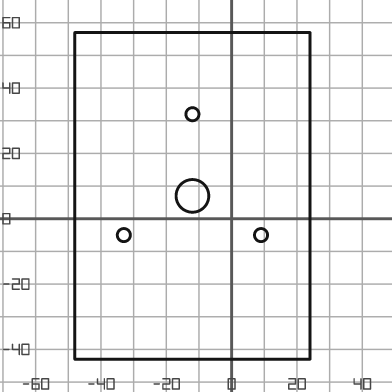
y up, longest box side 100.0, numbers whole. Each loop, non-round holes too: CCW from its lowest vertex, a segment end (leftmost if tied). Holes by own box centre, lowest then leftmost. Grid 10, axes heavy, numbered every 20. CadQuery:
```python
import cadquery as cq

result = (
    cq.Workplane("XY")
    .moveTo(-48.0, -43.0)
    .lineTo(24.0, -43.0)
    .lineTo(24.0, 57.0)
    .lineTo(-48.0, 57.0)
    .close()
    .moveTo(-33.0, -5.0)
    .circle(2.0)
    .moveTo(9.0, -5.0)
    .circle(2.0)
    .moveTo(-12.0, 7.0)
    .circle(5.0)
    .moveTo(-12.0, 32.0)
    .circle(2.0)
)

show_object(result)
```